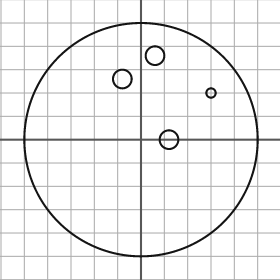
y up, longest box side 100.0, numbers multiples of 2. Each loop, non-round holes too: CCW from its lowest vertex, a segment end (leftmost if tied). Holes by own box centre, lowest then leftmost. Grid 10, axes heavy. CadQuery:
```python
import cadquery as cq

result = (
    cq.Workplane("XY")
    .moveTo(0.0, 0.0)
    .circle(50.0)
    .moveTo(12.0, 0.0)
    .circle(4.0)
    .moveTo(30.0, 20.0)
    .circle(2.0)
    .moveTo(-8.0, 26.0)
    .circle(4.0)
    .moveTo(6.0, 36.0)
    .circle(4.0)
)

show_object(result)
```